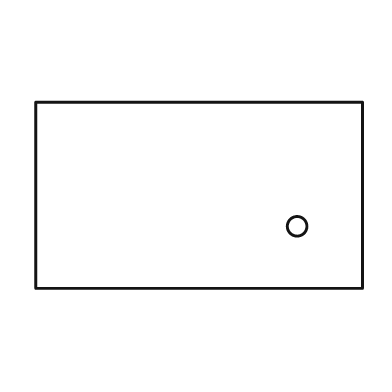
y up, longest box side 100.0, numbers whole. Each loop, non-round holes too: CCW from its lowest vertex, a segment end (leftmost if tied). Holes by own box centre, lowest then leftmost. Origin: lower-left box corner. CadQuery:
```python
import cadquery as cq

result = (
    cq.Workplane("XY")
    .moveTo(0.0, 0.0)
    .lineTo(100.0, 0.0)
    .lineTo(100.0, 57.0)
    .lineTo(0.0, 57.0)
    .close()
    .moveTo(80.0, 19.0)
    .circle(3.0)
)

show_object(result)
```